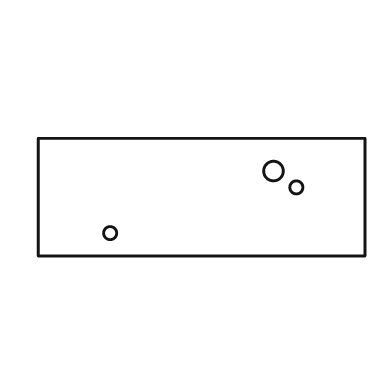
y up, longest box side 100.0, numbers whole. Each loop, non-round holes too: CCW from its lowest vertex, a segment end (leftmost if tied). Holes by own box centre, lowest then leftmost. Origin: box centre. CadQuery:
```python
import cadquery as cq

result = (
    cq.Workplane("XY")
    .moveTo(-50.0, -18.0)
    .lineTo(50.0, -18.0)
    .lineTo(50.0, 18.0)
    .lineTo(-50.0, 18.0)
    .close()
    .moveTo(-28.0, -11.0)
    .circle(2.0)
    .moveTo(29.0, 3.0)
    .circle(2.0)
    .moveTo(22.0, 8.0)
    .circle(3.0)
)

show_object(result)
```